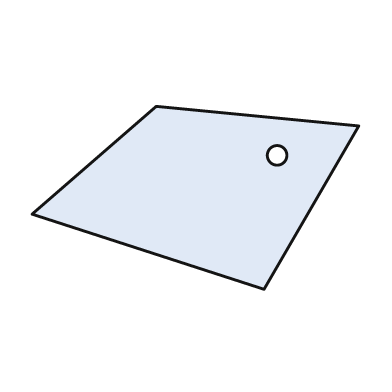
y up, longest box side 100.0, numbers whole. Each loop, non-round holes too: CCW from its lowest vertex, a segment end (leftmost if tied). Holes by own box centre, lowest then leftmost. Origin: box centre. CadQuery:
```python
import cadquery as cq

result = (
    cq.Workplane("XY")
    .moveTo(21.0, -28.0)
    .lineTo(50.0, 22.0)
    .lineTo(-12.0, 28.0)
    .lineTo(-50.0, -5.0)
    .close()
    .moveTo(25.0, 13.0)
    .circle(3.0)
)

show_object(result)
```